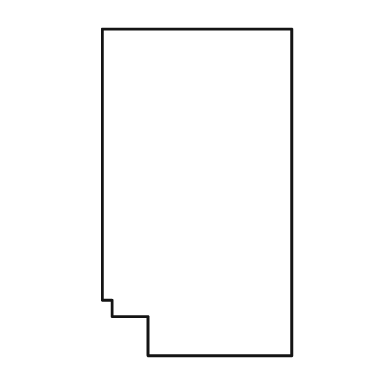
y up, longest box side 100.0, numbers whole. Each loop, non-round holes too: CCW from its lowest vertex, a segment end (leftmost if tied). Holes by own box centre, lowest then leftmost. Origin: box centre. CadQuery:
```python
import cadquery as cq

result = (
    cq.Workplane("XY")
    .moveTo(-15.0, -50.0)
    .lineTo(29.0, -50.0)
    .lineTo(29.0, 50.0)
    .lineTo(-29.0, 50.0)
    .lineTo(-29.0, -33.0)
    .lineTo(-26.0, -33.0)
    .lineTo(-26.0, -38.0)
    .lineTo(-15.0, -38.0)
    .close()
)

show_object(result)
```